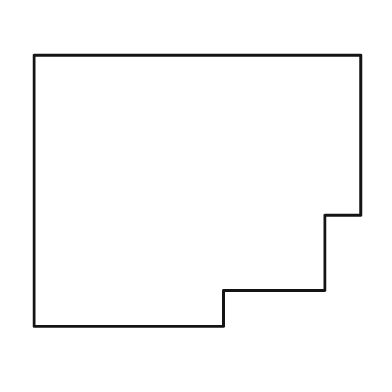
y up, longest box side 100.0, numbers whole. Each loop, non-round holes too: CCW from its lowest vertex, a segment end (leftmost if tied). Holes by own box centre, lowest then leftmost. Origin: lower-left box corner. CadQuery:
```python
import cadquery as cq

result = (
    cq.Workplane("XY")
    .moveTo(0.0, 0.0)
    .lineTo(58.0, 0.0)
    .lineTo(58.0, 11.0)
    .lineTo(89.0, 11.0)
    .lineTo(89.0, 34.0)
    .lineTo(100.0, 34.0)
    .lineTo(100.0, 83.0)
    .lineTo(0.0, 83.0)
    .close()
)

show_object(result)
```